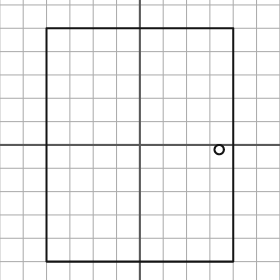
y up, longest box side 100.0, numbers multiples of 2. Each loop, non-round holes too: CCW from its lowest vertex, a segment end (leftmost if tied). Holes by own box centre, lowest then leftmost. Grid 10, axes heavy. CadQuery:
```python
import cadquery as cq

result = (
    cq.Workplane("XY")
    .moveTo(-40.0, -50.0)
    .lineTo(40.0, -50.0)
    .lineTo(40.0, 50.0)
    .lineTo(-40.0, 50.0)
    .close()
    .moveTo(34.0, -2.0)
    .circle(2.0)
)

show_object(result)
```